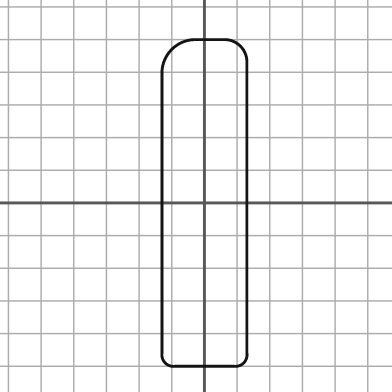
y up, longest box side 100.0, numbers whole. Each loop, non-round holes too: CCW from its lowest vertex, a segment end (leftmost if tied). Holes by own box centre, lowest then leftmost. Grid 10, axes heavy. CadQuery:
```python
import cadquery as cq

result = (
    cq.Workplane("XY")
    .moveTo(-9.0, -50.0)
    .lineTo(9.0, -50.0)
    .threePointArc((12.0, -49.0), (13.0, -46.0))
    .lineTo(13.0, 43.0)
    .threePointArc((11.0, 48.0), (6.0, 50.0))
    .lineTo(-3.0, 50.0)
    .threePointArc((-10.0, 47.0), (-13.0, 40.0))
    .lineTo(-13.0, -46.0)
    .threePointArc((-12.0, -49.0), (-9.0, -50.0))
    .close()
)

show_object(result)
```